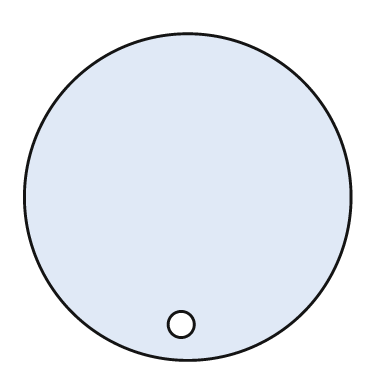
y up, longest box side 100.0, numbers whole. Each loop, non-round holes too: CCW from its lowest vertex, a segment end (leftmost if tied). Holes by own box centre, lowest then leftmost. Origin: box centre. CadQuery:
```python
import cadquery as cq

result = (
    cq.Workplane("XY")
    .moveTo(0.0, 0.0)
    .circle(50.0)
    .moveTo(-2.0, -39.0)
    .circle(4.0)
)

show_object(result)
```